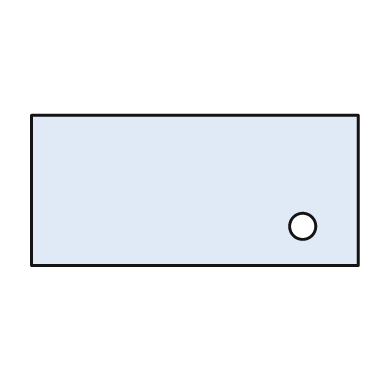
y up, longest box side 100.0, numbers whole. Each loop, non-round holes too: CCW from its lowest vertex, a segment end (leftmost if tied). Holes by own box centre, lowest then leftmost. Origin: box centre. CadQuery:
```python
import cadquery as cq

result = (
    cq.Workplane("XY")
    .moveTo(-50.0, -23.0)
    .lineTo(50.0, -23.0)
    .lineTo(50.0, 23.0)
    .lineTo(-50.0, 23.0)
    .close()
    .moveTo(33.0, -11.0)
    .circle(4.0)
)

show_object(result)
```